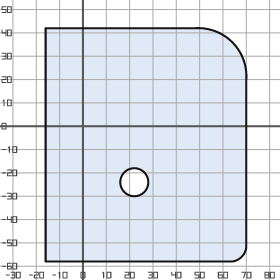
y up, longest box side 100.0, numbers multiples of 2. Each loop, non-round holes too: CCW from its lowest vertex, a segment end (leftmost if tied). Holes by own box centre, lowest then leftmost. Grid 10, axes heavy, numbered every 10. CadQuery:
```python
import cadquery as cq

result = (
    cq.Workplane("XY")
    .moveTo(-16.0, -58.0)
    .lineTo(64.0, -58.0)
    .threePointArc((68.0, -56.0), (70.0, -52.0))
    .lineTo(70.0, 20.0)
    .threePointArc((64.0, 36.0), (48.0, 42.0))
    .lineTo(-16.0, 42.0)
    .close()
    .moveTo(22.0, -24.0)
    .circle(6.0)
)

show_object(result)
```